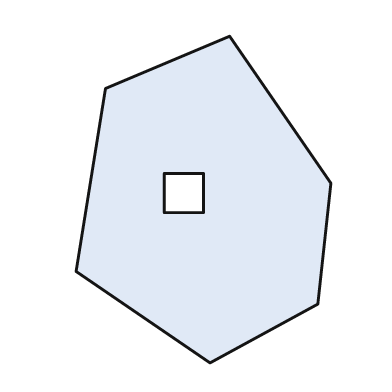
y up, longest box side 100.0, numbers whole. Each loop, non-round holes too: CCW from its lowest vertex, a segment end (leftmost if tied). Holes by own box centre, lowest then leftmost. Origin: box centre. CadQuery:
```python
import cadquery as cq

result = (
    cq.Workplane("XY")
    .moveTo(2.0, -50.0)
    .lineTo(35.0, -32.0)
    .lineTo(39.0, 5.0)
    .lineTo(8.0, 50.0)
    .lineTo(-30.0, 34.0)
    .lineTo(-39.0, -22.0)
    .close()
    .moveTo(-12.0, -4.0)
    .lineTo(0.0, -4.0)
    .lineTo(0.0, 8.0)
    .lineTo(-12.0, 8.0)
    .close()
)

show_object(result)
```